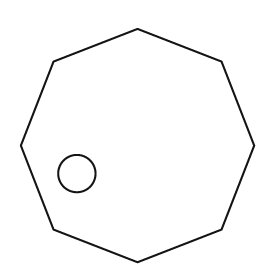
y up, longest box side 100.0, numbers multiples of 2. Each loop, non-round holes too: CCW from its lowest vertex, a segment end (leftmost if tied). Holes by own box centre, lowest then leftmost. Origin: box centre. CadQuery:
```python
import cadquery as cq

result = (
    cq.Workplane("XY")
    .moveTo(0.0, -50.0)
    .lineTo(36.0, -36.0)
    .lineTo(50.0, 0.0)
    .lineTo(36.0, 36.0)
    .lineTo(0.0, 50.0)
    .lineTo(-36.0, 36.0)
    .lineTo(-50.0, 0.0)
    .lineTo(-36.0, -36.0)
    .close()
    .moveTo(-26.0, -12.0)
    .circle(8.0)
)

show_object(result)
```